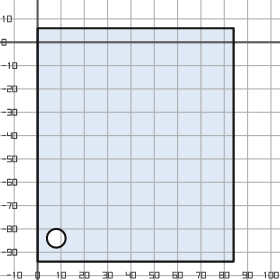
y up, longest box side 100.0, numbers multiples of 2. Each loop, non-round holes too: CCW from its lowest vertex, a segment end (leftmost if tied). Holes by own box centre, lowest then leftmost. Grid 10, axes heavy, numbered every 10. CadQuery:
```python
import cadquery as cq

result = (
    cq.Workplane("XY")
    .moveTo(0.0, -94.0)
    .lineTo(84.0, -94.0)
    .lineTo(84.0, 6.0)
    .lineTo(0.0, 6.0)
    .close()
    .moveTo(8.0, -84.0)
    .circle(4.0)
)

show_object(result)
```